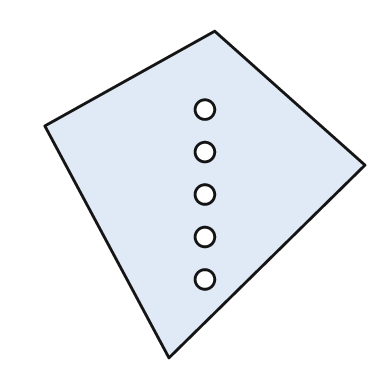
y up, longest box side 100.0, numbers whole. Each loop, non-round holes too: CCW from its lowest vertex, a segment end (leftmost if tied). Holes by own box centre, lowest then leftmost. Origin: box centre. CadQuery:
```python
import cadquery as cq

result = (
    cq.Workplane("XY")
    .moveTo(-11.0, -50.0)
    .lineTo(49.0, 9.0)
    .lineTo(3.0, 50.0)
    .lineTo(-49.0, 21.0)
    .close()
    .moveTo(0.0, -26.0)
    .circle(3.0)
    .moveTo(0.0, -13.0)
    .circle(3.0)
    .moveTo(0.0, 0.0)
    .circle(3.0)
    .moveTo(0.0, 13.0)
    .circle(3.0)
    .moveTo(0.0, 26.0)
    .circle(3.0)
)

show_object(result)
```